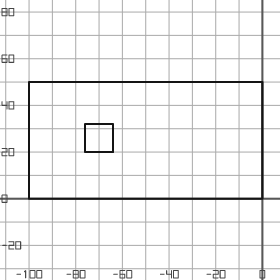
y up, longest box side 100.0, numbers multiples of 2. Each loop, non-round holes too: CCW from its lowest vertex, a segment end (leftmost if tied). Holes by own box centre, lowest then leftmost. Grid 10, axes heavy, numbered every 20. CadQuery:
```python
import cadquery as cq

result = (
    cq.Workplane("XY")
    .moveTo(-100.0, 0.0)
    .lineTo(0.0, 0.0)
    .lineTo(0.0, 50.0)
    .lineTo(-100.0, 50.0)
    .close()
    .moveTo(-76.0, 20.0)
    .lineTo(-64.0, 20.0)
    .lineTo(-64.0, 32.0)
    .lineTo(-76.0, 32.0)
    .close()
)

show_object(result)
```